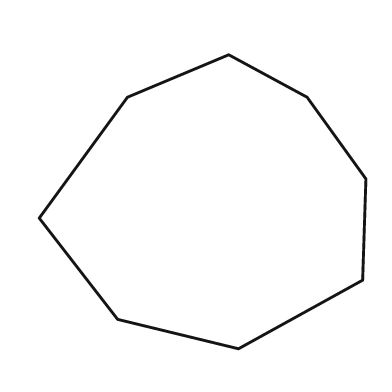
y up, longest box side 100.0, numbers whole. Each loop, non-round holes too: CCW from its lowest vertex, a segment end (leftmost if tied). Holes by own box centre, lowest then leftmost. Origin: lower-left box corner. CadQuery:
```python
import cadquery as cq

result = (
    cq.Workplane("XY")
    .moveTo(61.0, 0.0)
    .lineTo(99.0, 21.0)
    .lineTo(100.0, 52.0)
    .lineTo(82.0, 77.0)
    .lineTo(58.0, 90.0)
    .lineTo(27.0, 77.0)
    .lineTo(0.0, 40.0)
    .lineTo(24.0, 9.0)
    .close()
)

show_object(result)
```